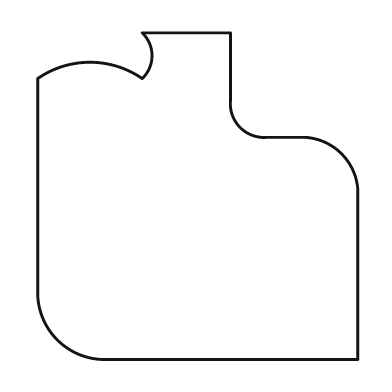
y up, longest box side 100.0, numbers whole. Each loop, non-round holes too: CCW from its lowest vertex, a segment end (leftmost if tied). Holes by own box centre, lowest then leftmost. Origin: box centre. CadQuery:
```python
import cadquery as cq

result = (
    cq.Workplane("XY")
    .moveTo(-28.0, -50.0)
    .lineTo(49.0, -50.0)
    .lineTo(49.0, 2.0)
    .threePointArc((44.0, 13.0), (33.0, 18.0))
    .lineTo(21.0, 18.0)
    .threePointArc((13.0, 21.0), (10.0, 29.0))
    .lineTo(10.0, 50.0)
    .lineTo(-17.0, 50.0)
    .threePointArc((-14.0, 43.0), (-17.0, 36.0))
    .threePointArc((-33.0, 41.0), (-49.0, 36.0))
    .lineTo(-49.0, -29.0)
    .threePointArc((-43.0, -44.0), (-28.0, -50.0))
    .close()
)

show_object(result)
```